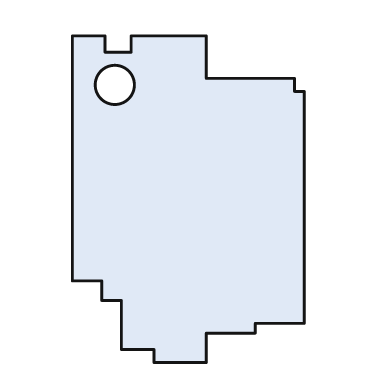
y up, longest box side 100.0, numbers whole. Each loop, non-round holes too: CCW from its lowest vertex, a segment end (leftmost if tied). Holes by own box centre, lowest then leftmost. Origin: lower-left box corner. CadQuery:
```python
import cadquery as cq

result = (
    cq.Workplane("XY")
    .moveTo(25.0, 0.0)
    .lineTo(41.0, 0.0)
    .lineTo(41.0, 9.0)
    .lineTo(56.0, 9.0)
    .lineTo(56.0, 12.0)
    .lineTo(71.0, 12.0)
    .lineTo(71.0, 83.0)
    .lineTo(68.0, 83.0)
    .lineTo(68.0, 87.0)
    .lineTo(41.0, 87.0)
    .lineTo(41.0, 100.0)
    .lineTo(18.0, 100.0)
    .lineTo(18.0, 95.0)
    .lineTo(10.0, 95.0)
    .lineTo(10.0, 100.0)
    .lineTo(0.0, 100.0)
    .lineTo(0.0, 25.0)
    .lineTo(9.0, 25.0)
    .lineTo(9.0, 19.0)
    .lineTo(15.0, 19.0)
    .lineTo(15.0, 4.0)
    .lineTo(25.0, 4.0)
    .close()
    .moveTo(13.0, 85.0)
    .circle(6.0)
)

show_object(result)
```